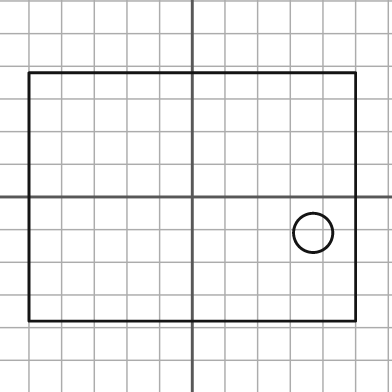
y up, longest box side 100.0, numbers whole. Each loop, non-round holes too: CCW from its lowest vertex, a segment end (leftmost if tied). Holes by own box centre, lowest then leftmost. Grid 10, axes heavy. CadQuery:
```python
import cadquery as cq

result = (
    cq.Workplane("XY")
    .moveTo(-50.0, -38.0)
    .lineTo(50.0, -38.0)
    .lineTo(50.0, 38.0)
    .lineTo(-50.0, 38.0)
    .close()
    .moveTo(37.0, -11.0)
    .circle(6.0)
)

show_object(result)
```